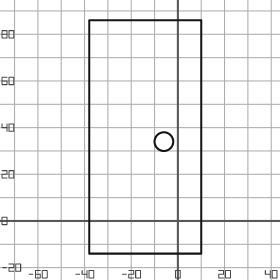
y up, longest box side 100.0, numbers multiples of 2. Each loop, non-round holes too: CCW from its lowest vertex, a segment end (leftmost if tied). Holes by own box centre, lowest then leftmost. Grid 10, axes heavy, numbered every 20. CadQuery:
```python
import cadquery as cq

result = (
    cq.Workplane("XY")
    .moveTo(-38.0, -14.0)
    .lineTo(10.0, -14.0)
    .lineTo(10.0, 86.0)
    .lineTo(-38.0, 86.0)
    .close()
    .moveTo(-6.0, 34.0)
    .circle(4.0)
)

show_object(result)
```